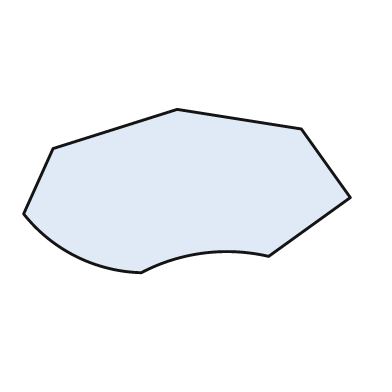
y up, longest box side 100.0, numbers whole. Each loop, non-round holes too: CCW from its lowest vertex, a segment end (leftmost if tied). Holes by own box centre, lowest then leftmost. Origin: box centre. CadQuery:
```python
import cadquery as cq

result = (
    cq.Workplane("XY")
    .moveTo(-14.0, -25.0)
    .threePointArc((5.0, -19.0), (25.0, -20.0))
    .lineTo(50.0, -2.0)
    .lineTo(35.0, 19.0)
    .lineTo(-3.0, 25.0)
    .lineTo(-41.0, 13.0)
    .lineTo(-50.0, -7.0)
    .threePointArc((-34.0, -20.0), (-14.0, -25.0))
    .close()
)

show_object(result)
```